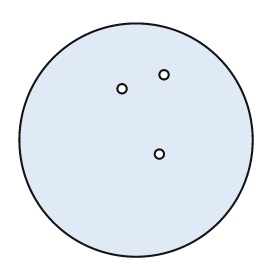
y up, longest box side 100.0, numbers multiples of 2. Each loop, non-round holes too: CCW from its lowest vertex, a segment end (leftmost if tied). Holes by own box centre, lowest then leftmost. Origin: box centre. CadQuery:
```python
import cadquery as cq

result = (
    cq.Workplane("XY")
    .moveTo(0.0, 0.0)
    .circle(50.0)
    .moveTo(10.0, -6.0)
    .circle(2.0)
    .moveTo(-6.0, 22.0)
    .circle(2.0)
    .moveTo(12.0, 28.0)
    .circle(2.0)
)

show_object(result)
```